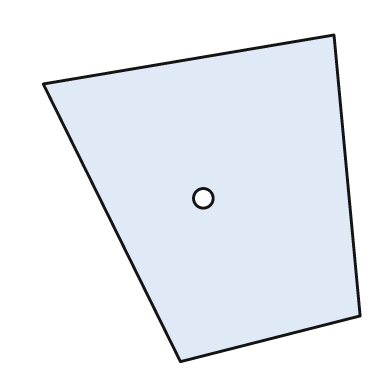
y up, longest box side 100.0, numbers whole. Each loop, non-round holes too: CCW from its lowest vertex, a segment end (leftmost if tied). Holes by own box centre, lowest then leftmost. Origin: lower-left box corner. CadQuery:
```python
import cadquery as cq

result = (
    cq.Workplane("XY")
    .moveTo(42.0, 0.0)
    .lineTo(97.0, 14.0)
    .lineTo(89.0, 100.0)
    .lineTo(0.0, 85.0)
    .close()
    .moveTo(49.0, 50.0)
    .circle(3.0)
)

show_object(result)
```